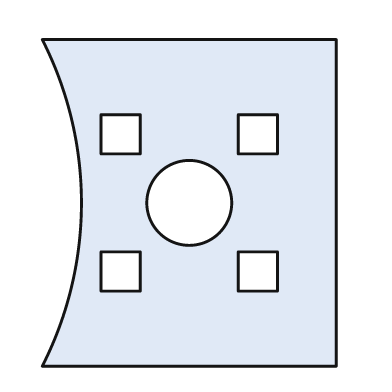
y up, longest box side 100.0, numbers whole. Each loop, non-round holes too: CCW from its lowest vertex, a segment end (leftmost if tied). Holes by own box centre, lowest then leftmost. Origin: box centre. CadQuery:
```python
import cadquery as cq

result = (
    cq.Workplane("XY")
    .moveTo(-45.0, -50.0)
    .lineTo(45.0, -50.0)
    .lineTo(45.0, 50.0)
    .lineTo(-45.0, 50.0)
    .threePointArc((-33.0, 0.0), (-45.0, -50.0))
    .close()
    .moveTo(-27.0, -27.0)
    .lineTo(-15.0, -27.0)
    .lineTo(-15.0, -15.0)
    .lineTo(-27.0, -15.0)
    .close()
    .moveTo(15.0, -27.0)
    .lineTo(27.0, -27.0)
    .lineTo(27.0, -15.0)
    .lineTo(15.0, -15.0)
    .close()
    .moveTo(0.0, 0.0)
    .circle(13.0)
    .moveTo(-27.0, 15.0)
    .lineTo(-15.0, 15.0)
    .lineTo(-15.0, 27.0)
    .lineTo(-27.0, 27.0)
    .close()
    .moveTo(15.0, 15.0)
    .lineTo(27.0, 15.0)
    .lineTo(27.0, 27.0)
    .lineTo(15.0, 27.0)
    .close()
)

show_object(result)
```